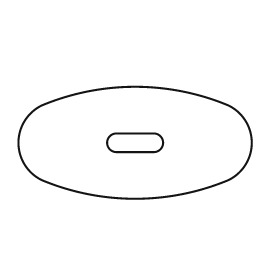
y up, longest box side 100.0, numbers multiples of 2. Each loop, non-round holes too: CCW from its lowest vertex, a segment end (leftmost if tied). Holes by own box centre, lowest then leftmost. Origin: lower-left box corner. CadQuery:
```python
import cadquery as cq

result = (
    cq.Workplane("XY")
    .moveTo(10.0, 8.0)
    .threePointArc((50.0, 0.0), (90.0, 8.0))
    .threePointArc((100.0, 24.0), (90.0, 40.0))
    .threePointArc((50.0, 48.0), (10.0, 40.0))
    .threePointArc((0.0, 24.0), (10.0, 8.0))
    .close()
    .moveTo(42.0, 20.0)
    .lineTo(58.0, 20.0)
    .threePointArc((62.0, 24.0), (58.0, 28.0))
    .lineTo(42.0, 28.0)
    .threePointArc((38.0, 24.0), (42.0, 20.0))
    .close()
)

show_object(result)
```